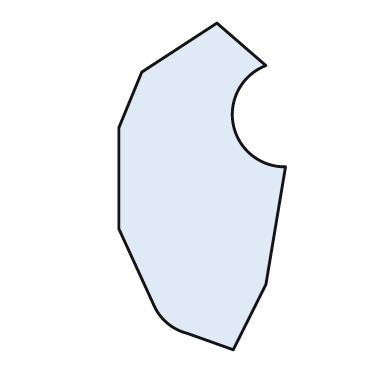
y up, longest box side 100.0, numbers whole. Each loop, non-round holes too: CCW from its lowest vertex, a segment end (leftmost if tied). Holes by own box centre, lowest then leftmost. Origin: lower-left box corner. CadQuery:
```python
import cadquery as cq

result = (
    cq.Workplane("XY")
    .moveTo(35.0, 0.0)
    .lineTo(45.0, 20.0)
    .lineTo(51.0, 56.0)
    .threePointArc((35.0, 69.0), (45.0, 87.0))
    .lineTo(30.0, 100.0)
    .lineTo(7.0, 85.0)
    .lineTo(0.0, 68.0)
    .lineTo(0.0, 37.0)
    .lineTo(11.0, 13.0)
    .threePointArc((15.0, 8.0), (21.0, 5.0))
    .close()
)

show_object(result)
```